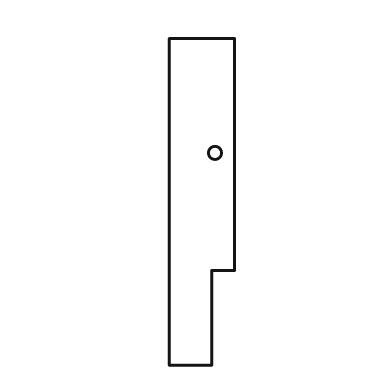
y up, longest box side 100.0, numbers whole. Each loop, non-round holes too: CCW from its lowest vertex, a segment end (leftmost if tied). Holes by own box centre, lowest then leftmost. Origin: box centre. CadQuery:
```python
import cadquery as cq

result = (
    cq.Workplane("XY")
    .moveTo(-10.0, -50.0)
    .lineTo(3.0, -50.0)
    .lineTo(3.0, -21.0)
    .lineTo(10.0, -21.0)
    .lineTo(10.0, 50.0)
    .lineTo(-10.0, 50.0)
    .close()
    .moveTo(4.0, 15.0)
    .circle(2.0)
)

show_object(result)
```